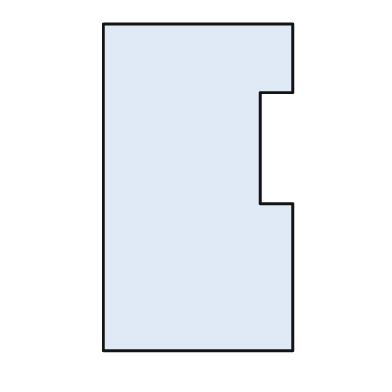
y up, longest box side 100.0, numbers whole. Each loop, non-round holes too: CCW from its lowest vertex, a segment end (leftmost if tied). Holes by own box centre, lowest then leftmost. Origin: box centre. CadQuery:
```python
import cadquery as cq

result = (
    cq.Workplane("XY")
    .moveTo(-29.0, -50.0)
    .lineTo(29.0, -50.0)
    .lineTo(29.0, -5.0)
    .lineTo(19.0, -5.0)
    .lineTo(19.0, 29.0)
    .lineTo(29.0, 29.0)
    .lineTo(29.0, 50.0)
    .lineTo(-29.0, 50.0)
    .close()
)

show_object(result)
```